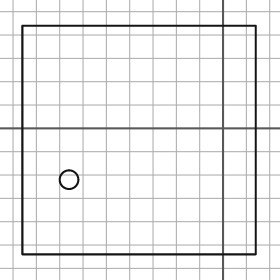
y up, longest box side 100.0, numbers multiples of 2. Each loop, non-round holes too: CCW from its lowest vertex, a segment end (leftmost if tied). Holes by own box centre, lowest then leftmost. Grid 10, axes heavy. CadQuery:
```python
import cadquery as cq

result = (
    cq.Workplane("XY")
    .moveTo(-86.0, -54.0)
    .lineTo(14.0, -54.0)
    .lineTo(14.0, 44.0)
    .lineTo(-86.0, 44.0)
    .close()
    .moveTo(-66.0, -22.0)
    .circle(4.0)
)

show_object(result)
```